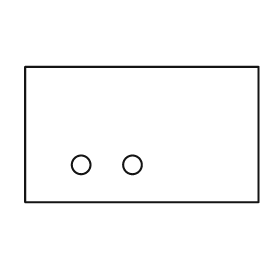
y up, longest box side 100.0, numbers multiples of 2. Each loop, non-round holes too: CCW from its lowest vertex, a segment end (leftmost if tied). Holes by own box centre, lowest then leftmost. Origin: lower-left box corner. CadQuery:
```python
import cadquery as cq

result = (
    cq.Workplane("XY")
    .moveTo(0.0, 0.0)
    .lineTo(100.0, 0.0)
    .lineTo(100.0, 58.0)
    .lineTo(0.0, 58.0)
    .close()
    .moveTo(24.0, 16.0)
    .circle(4.0)
    .moveTo(46.0, 16.0)
    .circle(4.0)
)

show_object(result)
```